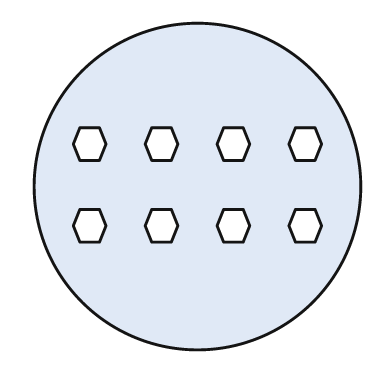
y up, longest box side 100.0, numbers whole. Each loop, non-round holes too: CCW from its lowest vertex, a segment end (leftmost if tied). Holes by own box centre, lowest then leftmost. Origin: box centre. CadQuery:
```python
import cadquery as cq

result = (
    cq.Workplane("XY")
    .moveTo(0.0, 0.0)
    .circle(50.0)
    .moveTo(-36.0, -17.0)
    .lineTo(-30.0, -17.0)
    .lineTo(-28.0, -12.0)
    .lineTo(-30.0, -7.0)
    .lineTo(-36.0, -7.0)
    .lineTo(-38.0, -12.0)
    .close()
    .moveTo(-14.0, -17.0)
    .lineTo(-8.0, -17.0)
    .lineTo(-6.0, -12.0)
    .lineTo(-8.0, -7.0)
    .lineTo(-14.0, -7.0)
    .lineTo(-16.0, -12.0)
    .close()
    .moveTo(8.0, -17.0)
    .lineTo(14.0, -17.0)
    .lineTo(16.0, -12.0)
    .lineTo(14.0, -7.0)
    .lineTo(8.0, -7.0)
    .lineTo(6.0, -12.0)
    .close()
    .moveTo(30.0, -17.0)
    .lineTo(36.0, -17.0)
    .lineTo(38.0, -12.0)
    .lineTo(36.0, -7.0)
    .lineTo(30.0, -7.0)
    .lineTo(28.0, -12.0)
    .close()
    .moveTo(-36.0, 8.0)
    .lineTo(-30.0, 8.0)
    .lineTo(-28.0, 13.0)
    .lineTo(-30.0, 18.0)
    .lineTo(-36.0, 18.0)
    .lineTo(-38.0, 13.0)
    .close()
    .moveTo(-14.0, 8.0)
    .lineTo(-8.0, 8.0)
    .lineTo(-6.0, 13.0)
    .lineTo(-8.0, 18.0)
    .lineTo(-14.0, 18.0)
    .lineTo(-16.0, 13.0)
    .close()
    .moveTo(8.0, 8.0)
    .lineTo(14.0, 8.0)
    .lineTo(16.0, 13.0)
    .lineTo(14.0, 18.0)
    .lineTo(8.0, 18.0)
    .lineTo(6.0, 13.0)
    .close()
    .moveTo(30.0, 8.0)
    .lineTo(36.0, 8.0)
    .lineTo(38.0, 13.0)
    .lineTo(36.0, 18.0)
    .lineTo(30.0, 18.0)
    .lineTo(28.0, 13.0)
    .close()
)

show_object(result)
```